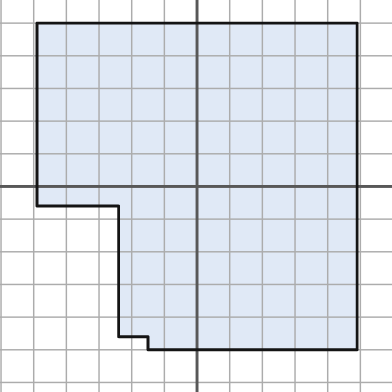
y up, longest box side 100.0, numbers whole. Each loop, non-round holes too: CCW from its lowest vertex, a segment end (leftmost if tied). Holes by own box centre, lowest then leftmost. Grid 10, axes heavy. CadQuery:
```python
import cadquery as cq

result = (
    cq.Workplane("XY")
    .moveTo(-15.0, -50.0)
    .lineTo(49.0, -50.0)
    .lineTo(49.0, 50.0)
    .lineTo(-49.0, 50.0)
    .lineTo(-49.0, -6.0)
    .lineTo(-24.0, -6.0)
    .lineTo(-24.0, -46.0)
    .lineTo(-15.0, -46.0)
    .close()
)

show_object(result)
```